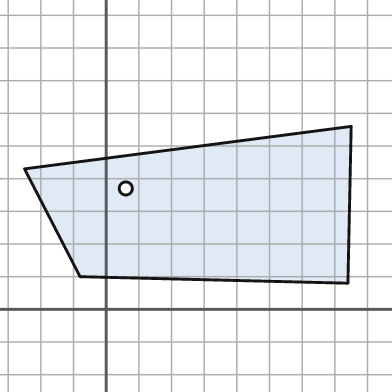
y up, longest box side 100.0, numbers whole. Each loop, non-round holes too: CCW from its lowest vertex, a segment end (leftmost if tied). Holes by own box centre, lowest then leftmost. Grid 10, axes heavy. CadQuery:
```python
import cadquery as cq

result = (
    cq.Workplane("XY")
    .moveTo(74.0, 8.0)
    .lineTo(75.0, 56.0)
    .lineTo(-25.0, 43.0)
    .lineTo(-8.0, 10.0)
    .close()
    .moveTo(6.0, 37.0)
    .circle(2.0)
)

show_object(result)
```